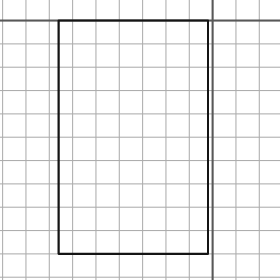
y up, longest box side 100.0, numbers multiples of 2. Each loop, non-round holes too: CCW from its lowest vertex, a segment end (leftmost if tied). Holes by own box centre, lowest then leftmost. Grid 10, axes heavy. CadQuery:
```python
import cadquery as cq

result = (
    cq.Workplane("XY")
    .moveTo(-66.0, -100.0)
    .lineTo(-2.0, -100.0)
    .lineTo(-2.0, 0.0)
    .lineTo(-66.0, 0.0)
    .close()
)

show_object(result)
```